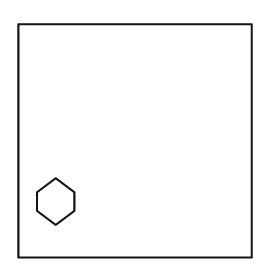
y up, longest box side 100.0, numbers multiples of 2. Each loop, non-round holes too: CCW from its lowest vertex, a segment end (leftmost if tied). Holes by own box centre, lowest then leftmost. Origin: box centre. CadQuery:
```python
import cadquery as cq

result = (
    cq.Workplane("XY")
    .moveTo(-50.0, -50.0)
    .lineTo(50.0, -50.0)
    .lineTo(50.0, 50.0)
    .lineTo(-50.0, 50.0)
    .close()
    .moveTo(-34.0, -36.0)
    .lineTo(-26.0, -30.0)
    .lineTo(-26.0, -22.0)
    .lineTo(-34.0, -16.0)
    .lineTo(-42.0, -22.0)
    .lineTo(-42.0, -30.0)
    .close()
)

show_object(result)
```